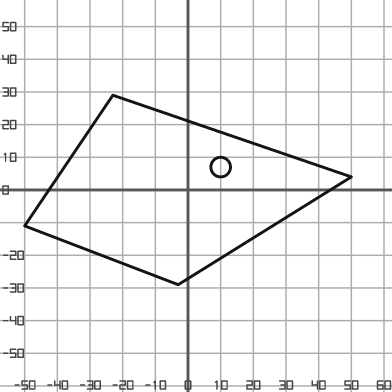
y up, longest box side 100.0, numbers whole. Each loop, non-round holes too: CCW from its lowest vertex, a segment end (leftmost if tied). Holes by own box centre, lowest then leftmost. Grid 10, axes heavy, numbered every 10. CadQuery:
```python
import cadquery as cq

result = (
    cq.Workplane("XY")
    .moveTo(-3.0, -29.0)
    .lineTo(50.0, 4.0)
    .lineTo(-23.0, 29.0)
    .lineTo(-50.0, -11.0)
    .close()
    .moveTo(10.0, 7.0)
    .circle(3.0)
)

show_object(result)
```